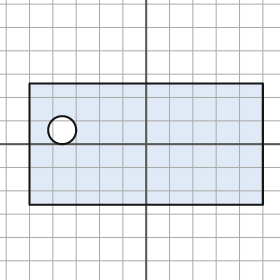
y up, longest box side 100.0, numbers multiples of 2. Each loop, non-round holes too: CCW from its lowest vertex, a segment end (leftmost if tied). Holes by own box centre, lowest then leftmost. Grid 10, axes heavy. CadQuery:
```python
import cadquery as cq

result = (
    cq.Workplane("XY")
    .moveTo(-50.0, -26.0)
    .lineTo(50.0, -26.0)
    .lineTo(50.0, 26.0)
    .lineTo(-50.0, 26.0)
    .close()
    .moveTo(-36.0, 6.0)
    .circle(6.0)
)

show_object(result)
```